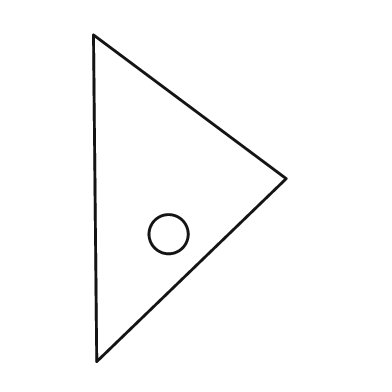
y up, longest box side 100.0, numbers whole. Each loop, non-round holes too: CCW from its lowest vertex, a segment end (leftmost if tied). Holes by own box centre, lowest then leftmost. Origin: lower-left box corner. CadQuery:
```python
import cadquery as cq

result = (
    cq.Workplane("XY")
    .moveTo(1.0, 0.0)
    .lineTo(59.0, 56.0)
    .lineTo(0.0, 100.0)
    .close()
    .moveTo(23.0, 39.0)
    .circle(6.0)
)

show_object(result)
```